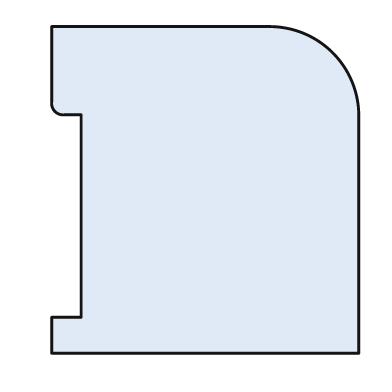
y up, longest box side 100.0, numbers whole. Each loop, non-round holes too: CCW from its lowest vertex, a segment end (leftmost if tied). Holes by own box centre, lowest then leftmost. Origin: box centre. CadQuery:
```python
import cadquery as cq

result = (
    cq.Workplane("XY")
    .moveTo(-47.0, -50.0)
    .lineTo(47.0, -50.0)
    .lineTo(47.0, 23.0)
    .threePointArc((39.0, 42.0), (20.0, 50.0))
    .lineTo(-47.0, 50.0)
    .lineTo(-47.0, 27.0)
    .threePointArc((-46.0, 24.0), (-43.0, 23.0))
    .lineTo(-38.0, 23.0)
    .lineTo(-38.0, -39.0)
    .lineTo(-47.0, -39.0)
    .close()
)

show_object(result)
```